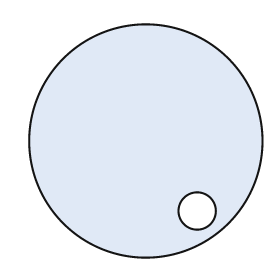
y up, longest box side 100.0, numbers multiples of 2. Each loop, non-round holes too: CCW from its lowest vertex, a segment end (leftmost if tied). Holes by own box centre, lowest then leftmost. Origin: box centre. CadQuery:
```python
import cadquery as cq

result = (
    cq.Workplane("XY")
    .moveTo(0.0, 0.0)
    .circle(50.0)
    .moveTo(22.0, -30.0)
    .circle(8.0)
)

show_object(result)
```